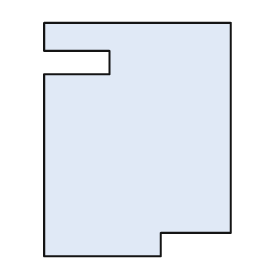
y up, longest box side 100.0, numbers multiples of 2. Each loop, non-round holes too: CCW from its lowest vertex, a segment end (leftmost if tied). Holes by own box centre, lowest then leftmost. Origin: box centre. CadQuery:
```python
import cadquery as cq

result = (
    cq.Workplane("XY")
    .moveTo(-40.0, -50.0)
    .lineTo(10.0, -50.0)
    .lineTo(10.0, -40.0)
    .lineTo(40.0, -40.0)
    .lineTo(40.0, 50.0)
    .lineTo(-40.0, 50.0)
    .lineTo(-40.0, 38.0)
    .lineTo(-12.0, 38.0)
    .lineTo(-12.0, 28.0)
    .lineTo(-40.0, 28.0)
    .close()
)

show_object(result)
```